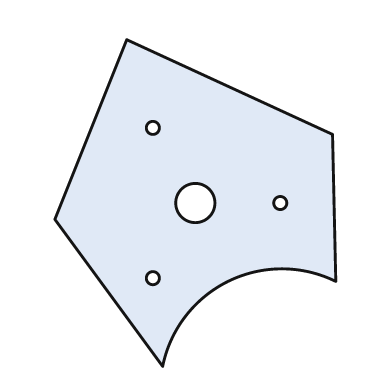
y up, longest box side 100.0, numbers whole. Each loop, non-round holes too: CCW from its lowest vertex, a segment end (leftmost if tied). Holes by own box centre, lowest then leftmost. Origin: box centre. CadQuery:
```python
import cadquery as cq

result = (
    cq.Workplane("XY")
    .moveTo(-10.0, -50.0)
    .threePointArc((10.0, -24.0), (43.0, -24.0))
    .lineTo(42.0, 21.0)
    .lineTo(-21.0, 50.0)
    .lineTo(-43.0, -5.0)
    .close()
    .moveTo(-13.0, -23.0)
    .circle(2.0)
    .moveTo(0.0, 0.0)
    .circle(6.0)
    .moveTo(26.0, 0.0)
    .circle(2.0)
    .moveTo(-13.0, 23.0)
    .circle(2.0)
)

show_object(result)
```